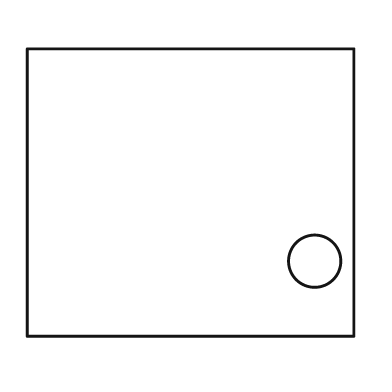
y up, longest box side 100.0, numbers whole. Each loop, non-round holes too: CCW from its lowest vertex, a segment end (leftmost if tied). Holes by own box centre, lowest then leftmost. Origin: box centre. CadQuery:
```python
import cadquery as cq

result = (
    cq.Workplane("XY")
    .moveTo(-50.0, -44.0)
    .lineTo(50.0, -44.0)
    .lineTo(50.0, 44.0)
    .lineTo(-50.0, 44.0)
    .close()
    .moveTo(38.0, -21.0)
    .circle(8.0)
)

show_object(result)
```